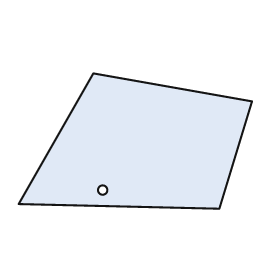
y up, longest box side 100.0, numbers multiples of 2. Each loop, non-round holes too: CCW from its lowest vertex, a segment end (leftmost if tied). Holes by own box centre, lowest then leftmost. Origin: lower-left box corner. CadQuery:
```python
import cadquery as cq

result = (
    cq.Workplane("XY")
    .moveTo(86.0, 0.0)
    .lineTo(100.0, 46.0)
    .lineTo(32.0, 58.0)
    .lineTo(0.0, 2.0)
    .close()
    .moveTo(36.0, 8.0)
    .circle(2.0)
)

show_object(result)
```